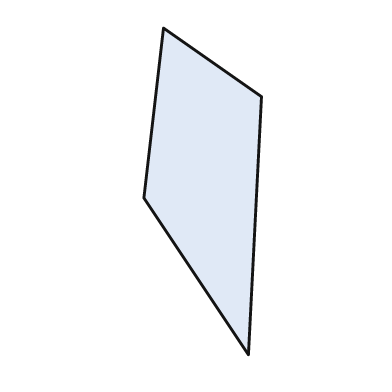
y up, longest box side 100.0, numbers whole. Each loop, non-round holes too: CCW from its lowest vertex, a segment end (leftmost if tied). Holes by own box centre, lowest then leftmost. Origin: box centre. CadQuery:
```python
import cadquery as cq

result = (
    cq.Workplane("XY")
    .moveTo(14.0, -50.0)
    .lineTo(18.0, 29.0)
    .lineTo(-12.0, 50.0)
    .lineTo(-18.0, -2.0)
    .close()
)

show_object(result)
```